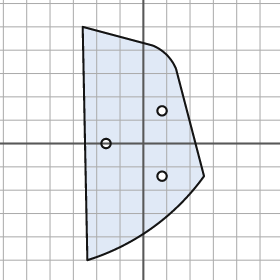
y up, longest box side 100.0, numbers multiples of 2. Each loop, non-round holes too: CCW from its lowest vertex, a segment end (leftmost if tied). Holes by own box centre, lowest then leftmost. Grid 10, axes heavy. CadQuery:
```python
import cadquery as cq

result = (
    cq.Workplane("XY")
    .moveTo(-24.0, -50.0)
    .threePointArc((4.0, -36.0), (26.0, -14.0))
    .lineTo(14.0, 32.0)
    .threePointArc((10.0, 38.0), (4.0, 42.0))
    .lineTo(-26.0, 50.0)
    .close()
    .moveTo(8.0, -14.0)
    .circle(2.0)
    .moveTo(-16.0, 0.0)
    .circle(2.0)
    .moveTo(8.0, 14.0)
    .circle(2.0)
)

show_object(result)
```